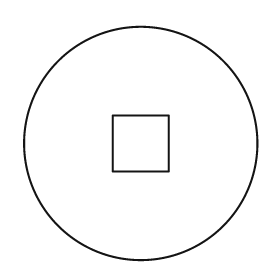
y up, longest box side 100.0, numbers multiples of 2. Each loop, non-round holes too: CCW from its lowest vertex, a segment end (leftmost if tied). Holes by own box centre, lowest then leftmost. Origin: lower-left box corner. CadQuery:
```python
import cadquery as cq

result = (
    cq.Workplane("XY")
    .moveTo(50.0, 50.0)
    .circle(50.0)
    .moveTo(38.0, 38.0)
    .lineTo(62.0, 38.0)
    .lineTo(62.0, 62.0)
    .lineTo(38.0, 62.0)
    .close()
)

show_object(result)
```